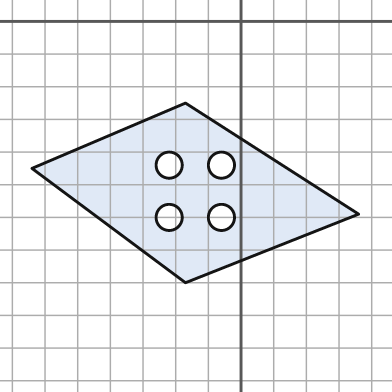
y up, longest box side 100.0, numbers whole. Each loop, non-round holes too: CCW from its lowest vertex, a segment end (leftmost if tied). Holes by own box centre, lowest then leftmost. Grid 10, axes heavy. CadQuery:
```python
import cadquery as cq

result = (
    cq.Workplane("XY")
    .moveTo(-17.0, -80.0)
    .lineTo(36.0, -59.0)
    .lineTo(-17.0, -25.0)
    .lineTo(-64.0, -45.0)
    .close()
    .moveTo(-22.0, -60.0)
    .circle(4.0)
    .moveTo(-6.0, -60.0)
    .circle(4.0)
    .moveTo(-22.0, -44.0)
    .circle(4.0)
    .moveTo(-6.0, -44.0)
    .circle(4.0)
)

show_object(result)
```